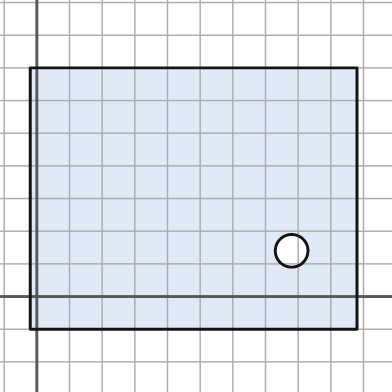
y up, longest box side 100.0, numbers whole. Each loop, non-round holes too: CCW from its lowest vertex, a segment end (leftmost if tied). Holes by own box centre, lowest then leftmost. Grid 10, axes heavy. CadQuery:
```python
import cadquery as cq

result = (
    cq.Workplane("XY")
    .moveTo(-2.0, -10.0)
    .lineTo(98.0, -10.0)
    .lineTo(98.0, 70.0)
    .lineTo(-2.0, 70.0)
    .close()
    .moveTo(78.0, 14.0)
    .circle(5.0)
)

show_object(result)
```